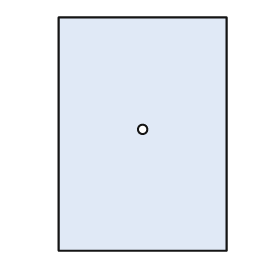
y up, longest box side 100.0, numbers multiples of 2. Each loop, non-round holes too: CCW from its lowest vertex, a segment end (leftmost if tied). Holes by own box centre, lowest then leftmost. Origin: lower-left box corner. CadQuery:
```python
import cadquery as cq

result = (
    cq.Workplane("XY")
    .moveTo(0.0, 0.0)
    .lineTo(72.0, 0.0)
    .lineTo(72.0, 100.0)
    .lineTo(0.0, 100.0)
    .close()
    .moveTo(36.0, 52.0)
    .circle(2.0)
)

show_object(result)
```